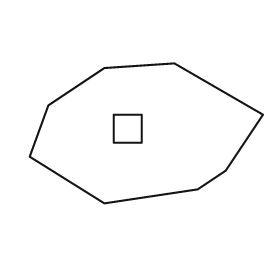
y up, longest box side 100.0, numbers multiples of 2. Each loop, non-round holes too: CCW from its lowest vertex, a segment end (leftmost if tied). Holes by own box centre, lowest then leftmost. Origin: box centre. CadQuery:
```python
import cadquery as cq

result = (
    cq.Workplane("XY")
    .moveTo(-18.0, -30.0)
    .lineTo(22.0, -24.0)
    .lineTo(34.0, -16.0)
    .lineTo(50.0, 8.0)
    .lineTo(12.0, 30.0)
    .lineTo(-18.0, 28.0)
    .lineTo(-42.0, 12.0)
    .lineTo(-50.0, -10.0)
    .close()
    .moveTo(-14.0, -4.0)
    .lineTo(-2.0, -4.0)
    .lineTo(-2.0, 8.0)
    .lineTo(-14.0, 8.0)
    .close()
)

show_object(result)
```